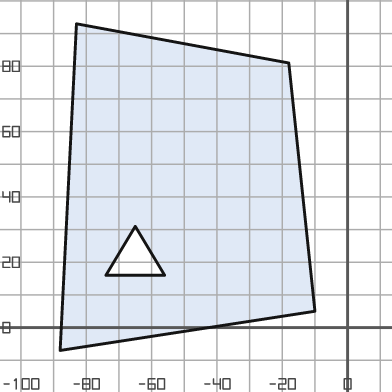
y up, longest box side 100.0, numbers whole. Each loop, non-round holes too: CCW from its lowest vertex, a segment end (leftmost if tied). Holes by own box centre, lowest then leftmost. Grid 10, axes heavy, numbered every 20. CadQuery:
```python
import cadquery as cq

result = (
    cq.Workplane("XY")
    .moveTo(-88.0, -7.0)
    .lineTo(-10.0, 5.0)
    .lineTo(-18.0, 81.0)
    .lineTo(-83.0, 93.0)
    .close()
    .moveTo(-74.0, 16.0)
    .lineTo(-56.0, 16.0)
    .lineTo(-65.0, 31.0)
    .close()
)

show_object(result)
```